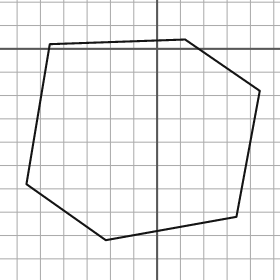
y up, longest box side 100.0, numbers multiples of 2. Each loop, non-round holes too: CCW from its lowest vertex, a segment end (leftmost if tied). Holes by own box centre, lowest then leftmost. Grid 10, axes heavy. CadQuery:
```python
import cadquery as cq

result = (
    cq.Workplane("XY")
    .moveTo(-22.0, -82.0)
    .lineTo(34.0, -72.0)
    .lineTo(44.0, -18.0)
    .lineTo(12.0, 4.0)
    .lineTo(-46.0, 2.0)
    .lineTo(-56.0, -58.0)
    .close()
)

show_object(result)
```